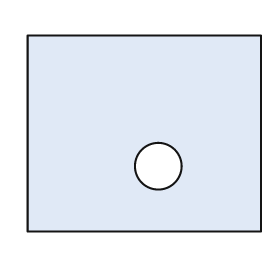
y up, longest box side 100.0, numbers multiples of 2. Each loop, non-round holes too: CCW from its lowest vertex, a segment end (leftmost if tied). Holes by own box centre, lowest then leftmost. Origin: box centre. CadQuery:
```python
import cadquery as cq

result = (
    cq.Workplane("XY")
    .moveTo(-50.0, -42.0)
    .lineTo(50.0, -42.0)
    .lineTo(50.0, 42.0)
    .lineTo(-50.0, 42.0)
    .close()
    .moveTo(6.0, -14.0)
    .circle(10.0)
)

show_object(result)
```